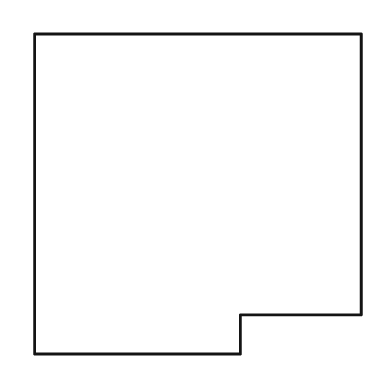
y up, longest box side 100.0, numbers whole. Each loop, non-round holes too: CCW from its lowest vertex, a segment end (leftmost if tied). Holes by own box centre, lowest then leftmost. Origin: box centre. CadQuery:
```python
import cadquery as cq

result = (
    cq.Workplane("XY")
    .moveTo(-50.0, -49.0)
    .lineTo(13.0, -49.0)
    .lineTo(13.0, -37.0)
    .lineTo(50.0, -37.0)
    .lineTo(50.0, 49.0)
    .lineTo(-50.0, 49.0)
    .close()
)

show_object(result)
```